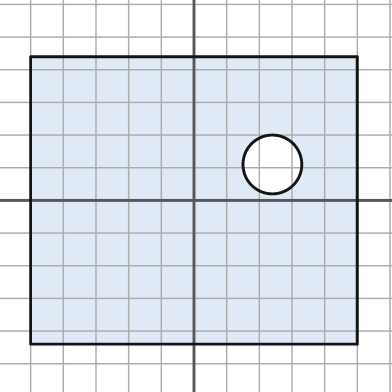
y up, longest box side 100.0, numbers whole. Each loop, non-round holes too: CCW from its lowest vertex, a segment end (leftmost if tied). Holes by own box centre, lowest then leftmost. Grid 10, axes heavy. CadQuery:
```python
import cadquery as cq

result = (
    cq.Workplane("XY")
    .moveTo(-50.0, -44.0)
    .lineTo(50.0, -44.0)
    .lineTo(50.0, 44.0)
    .lineTo(-50.0, 44.0)
    .close()
    .moveTo(24.0, 11.0)
    .circle(9.0)
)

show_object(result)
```